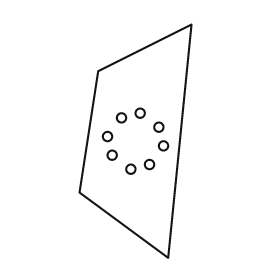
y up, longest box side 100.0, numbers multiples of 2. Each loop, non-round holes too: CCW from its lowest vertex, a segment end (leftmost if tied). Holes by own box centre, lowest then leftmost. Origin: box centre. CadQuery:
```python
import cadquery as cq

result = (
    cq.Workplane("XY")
    .moveTo(14.0, -50.0)
    .lineTo(24.0, 50.0)
    .lineTo(-16.0, 30.0)
    .lineTo(-24.0, -22.0)
    .close()
    .moveTo(-2.0, -12.0)
    .circle(2.0)
    .moveTo(6.0, -10.0)
    .circle(2.0)
    .moveTo(-10.0, -6.0)
    .circle(2.0)
    .moveTo(12.0, -2.0)
    .circle(2.0)
    .moveTo(-12.0, 2.0)
    .circle(2.0)
    .moveTo(10.0, 6.0)
    .circle(2.0)
    .moveTo(-6.0, 10.0)
    .circle(2.0)
    .moveTo(2.0, 12.0)
    .circle(2.0)
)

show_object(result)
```